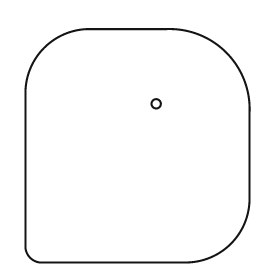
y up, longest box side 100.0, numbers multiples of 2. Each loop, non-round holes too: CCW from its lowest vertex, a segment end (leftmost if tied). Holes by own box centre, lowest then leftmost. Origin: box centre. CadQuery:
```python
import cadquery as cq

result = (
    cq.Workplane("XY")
    .moveTo(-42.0, -50.0)
    .lineTo(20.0, -50.0)
    .threePointArc((40.0, -42.0), (48.0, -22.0))
    .lineTo(48.0, 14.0)
    .threePointArc((38.0, 40.0), (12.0, 50.0))
    .lineTo(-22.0, 50.0)
    .threePointArc((-40.0, 42.0), (-48.0, 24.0))
    .lineTo(-48.0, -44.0)
    .threePointArc((-46.0, -48.0), (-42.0, -50.0))
    .close()
    .moveTo(8.0, 18.0)
    .circle(2.0)
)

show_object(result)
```